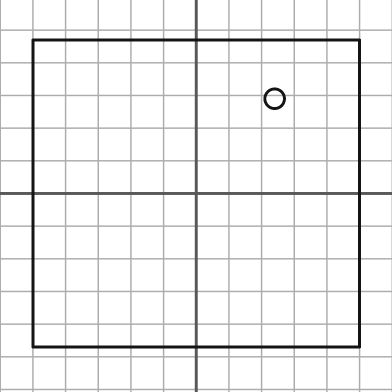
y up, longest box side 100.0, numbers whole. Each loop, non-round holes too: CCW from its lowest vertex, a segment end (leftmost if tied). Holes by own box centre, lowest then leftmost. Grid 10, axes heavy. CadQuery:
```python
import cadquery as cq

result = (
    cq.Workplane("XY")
    .moveTo(-50.0, -47.0)
    .lineTo(50.0, -47.0)
    .lineTo(50.0, 47.0)
    .lineTo(-50.0, 47.0)
    .close()
    .moveTo(24.0, 29.0)
    .circle(3.0)
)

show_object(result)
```